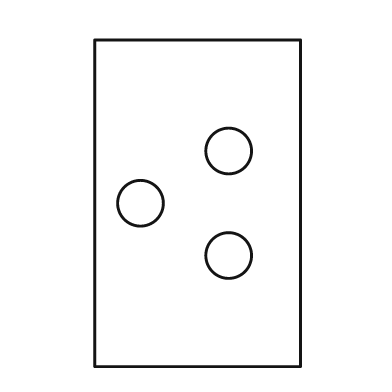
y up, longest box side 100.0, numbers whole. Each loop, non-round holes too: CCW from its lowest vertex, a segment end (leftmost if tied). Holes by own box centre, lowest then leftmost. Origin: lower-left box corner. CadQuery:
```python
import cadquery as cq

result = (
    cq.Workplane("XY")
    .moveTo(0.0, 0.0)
    .lineTo(63.0, 0.0)
    .lineTo(63.0, 100.0)
    .lineTo(0.0, 100.0)
    .close()
    .moveTo(41.0, 34.0)
    .circle(7.0)
    .moveTo(14.0, 50.0)
    .circle(7.0)
    .moveTo(41.0, 66.0)
    .circle(7.0)
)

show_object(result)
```